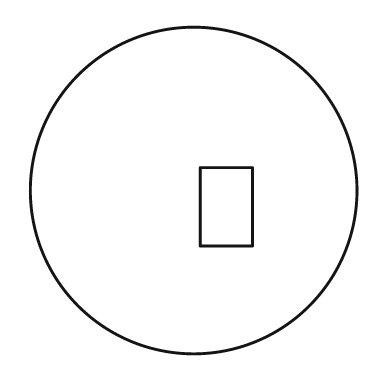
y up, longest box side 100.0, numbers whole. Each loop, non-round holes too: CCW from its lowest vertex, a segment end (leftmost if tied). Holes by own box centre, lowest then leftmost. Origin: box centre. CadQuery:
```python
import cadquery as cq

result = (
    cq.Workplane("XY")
    .moveTo(0.0, 0.0)
    .circle(50.0)
    .moveTo(2.0, -17.0)
    .lineTo(18.0, -17.0)
    .lineTo(18.0, 7.0)
    .lineTo(2.0, 7.0)
    .close()
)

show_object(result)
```